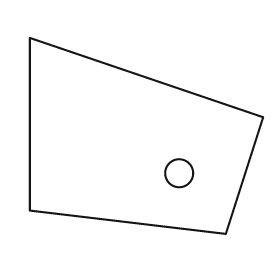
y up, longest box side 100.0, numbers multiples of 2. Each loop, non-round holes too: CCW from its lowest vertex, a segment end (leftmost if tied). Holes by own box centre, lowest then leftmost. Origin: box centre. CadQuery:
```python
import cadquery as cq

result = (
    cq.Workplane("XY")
    .moveTo(34.0, -42.0)
    .lineTo(50.0, 8.0)
    .lineTo(-50.0, 42.0)
    .lineTo(-50.0, -32.0)
    .close()
    .moveTo(14.0, -16.0)
    .circle(6.0)
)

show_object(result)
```